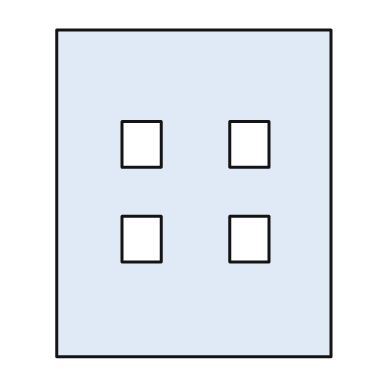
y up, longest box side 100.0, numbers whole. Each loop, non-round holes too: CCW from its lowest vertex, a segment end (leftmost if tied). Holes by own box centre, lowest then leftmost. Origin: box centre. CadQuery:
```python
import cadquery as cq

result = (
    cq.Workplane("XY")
    .moveTo(-42.0, -50.0)
    .lineTo(42.0, -50.0)
    .lineTo(42.0, 50.0)
    .lineTo(-42.0, 50.0)
    .close()
    .moveTo(-22.0, -21.0)
    .lineTo(-10.0, -21.0)
    .lineTo(-10.0, -7.0)
    .lineTo(-22.0, -7.0)
    .close()
    .moveTo(11.0, -21.0)
    .lineTo(23.0, -21.0)
    .lineTo(23.0, -7.0)
    .lineTo(11.0, -7.0)
    .close()
    .moveTo(-22.0, 8.0)
    .lineTo(-10.0, 8.0)
    .lineTo(-10.0, 22.0)
    .lineTo(-22.0, 22.0)
    .close()
    .moveTo(11.0, 8.0)
    .lineTo(23.0, 8.0)
    .lineTo(23.0, 22.0)
    .lineTo(11.0, 22.0)
    .close()
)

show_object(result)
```